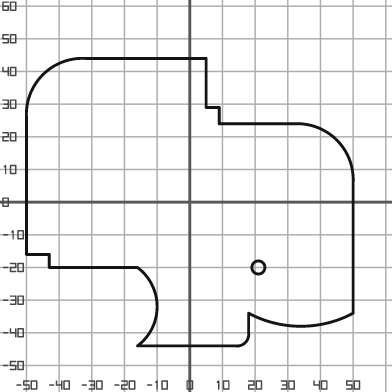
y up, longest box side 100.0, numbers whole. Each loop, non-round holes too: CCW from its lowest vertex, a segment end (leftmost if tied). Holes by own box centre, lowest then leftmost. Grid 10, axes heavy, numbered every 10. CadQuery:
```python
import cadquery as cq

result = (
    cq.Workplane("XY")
    .moveTo(-16.0, -44.0)
    .lineTo(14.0, -44.0)
    .threePointArc((17.0, -43.0), (18.0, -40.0))
    .lineTo(18.0, -34.0)
    .threePointArc((34.0, -38.0), (50.0, -34.0))
    .lineTo(50.0, 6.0)
    .threePointArc((45.0, 19.0), (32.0, 24.0))
    .lineTo(9.0, 24.0)
    .lineTo(9.0, 29.0)
    .lineTo(5.0, 29.0)
    .lineTo(5.0, 44.0)
    .lineTo(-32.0, 44.0)
    .threePointArc((-45.0, 39.0), (-50.0, 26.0))
    .lineTo(-50.0, -16.0)
    .lineTo(-43.0, -16.0)
    .lineTo(-43.0, -20.0)
    .lineTo(-16.0, -20.0)
    .threePointArc((-10.0, -32.0), (-16.0, -44.0))
    .close()
    .moveTo(21.0, -20.0)
    .circle(2.0)
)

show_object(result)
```